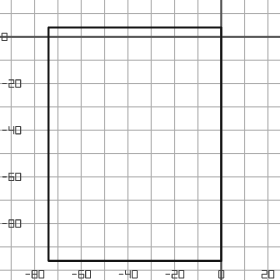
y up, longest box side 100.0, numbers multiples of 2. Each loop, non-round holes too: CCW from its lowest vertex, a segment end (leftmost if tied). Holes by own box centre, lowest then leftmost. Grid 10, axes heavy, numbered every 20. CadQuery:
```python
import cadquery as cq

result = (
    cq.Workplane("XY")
    .moveTo(-74.0, -96.0)
    .lineTo(0.0, -96.0)
    .lineTo(0.0, 4.0)
    .lineTo(-74.0, 4.0)
    .close()
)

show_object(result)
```